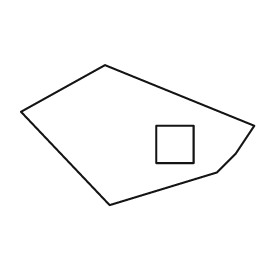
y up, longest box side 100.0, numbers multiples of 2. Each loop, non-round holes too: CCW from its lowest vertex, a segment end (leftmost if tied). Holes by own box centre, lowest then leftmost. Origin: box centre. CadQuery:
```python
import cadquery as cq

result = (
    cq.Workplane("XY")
    .moveTo(-12.0, -30.0)
    .lineTo(34.0, -16.0)
    .lineTo(42.0, -8.0)
    .lineTo(50.0, 4.0)
    .lineTo(-14.0, 30.0)
    .lineTo(-50.0, 10.0)
    .close()
    .moveTo(8.0, -12.0)
    .lineTo(24.0, -12.0)
    .lineTo(24.0, 4.0)
    .lineTo(8.0, 4.0)
    .close()
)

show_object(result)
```